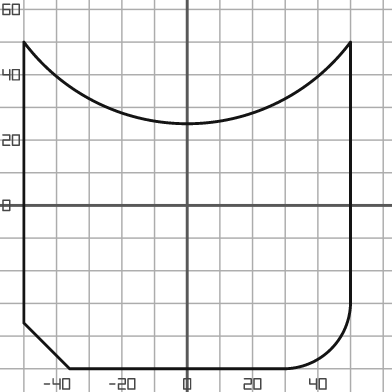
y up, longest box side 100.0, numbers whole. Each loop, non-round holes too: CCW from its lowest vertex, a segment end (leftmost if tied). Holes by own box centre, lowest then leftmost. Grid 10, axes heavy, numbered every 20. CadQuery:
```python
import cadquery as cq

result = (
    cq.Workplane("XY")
    .moveTo(-36.0, -50.0)
    .lineTo(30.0, -50.0)
    .threePointArc((44.0, -44.0), (50.0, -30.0))
    .lineTo(50.0, 50.0)
    .threePointArc((0.0, 25.0), (-50.0, 50.0))
    .lineTo(-50.0, -36.0)
    .close()
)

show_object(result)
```